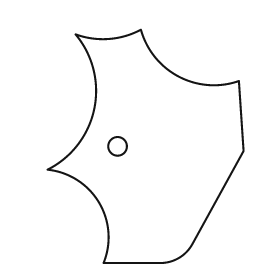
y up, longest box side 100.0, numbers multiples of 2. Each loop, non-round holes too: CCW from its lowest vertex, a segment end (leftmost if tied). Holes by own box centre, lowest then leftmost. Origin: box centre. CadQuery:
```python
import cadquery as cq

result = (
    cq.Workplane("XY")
    .moveTo(-18.0, -50.0)
    .lineTo(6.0, -50.0)
    .threePointArc((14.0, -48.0), (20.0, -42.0))
    .lineTo(42.0, -2.0)
    .lineTo(40.0, 28.0)
    .threePointArc((14.0, 30.0), (-2.0, 50.0))
    .threePointArc((-16.0, 46.0), (-30.0, 48.0))
    .threePointArc((-22.0, 16.0), (-42.0, -10.0))
    .threePointArc((-20.0, -24.0), (-18.0, -50.0))
    .close()
    .moveTo(-12.0, 0.0)
    .circle(4.0)
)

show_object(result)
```